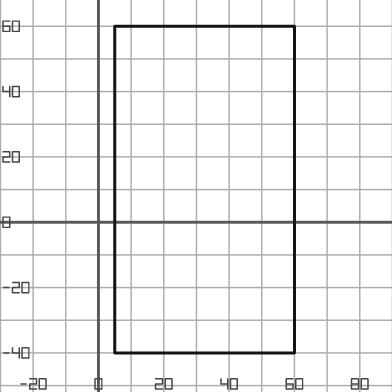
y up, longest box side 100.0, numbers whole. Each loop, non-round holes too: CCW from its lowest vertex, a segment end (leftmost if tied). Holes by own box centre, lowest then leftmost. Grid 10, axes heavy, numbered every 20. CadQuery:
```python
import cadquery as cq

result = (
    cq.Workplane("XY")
    .moveTo(5.0, -40.0)
    .lineTo(60.0, -40.0)
    .lineTo(60.0, 60.0)
    .lineTo(5.0, 60.0)
    .close()
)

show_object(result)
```